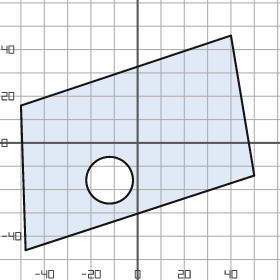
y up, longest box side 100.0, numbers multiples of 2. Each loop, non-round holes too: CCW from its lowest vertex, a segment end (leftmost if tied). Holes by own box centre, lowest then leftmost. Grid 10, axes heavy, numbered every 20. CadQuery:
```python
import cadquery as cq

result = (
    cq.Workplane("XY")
    .moveTo(-48.0, -46.0)
    .lineTo(50.0, -14.0)
    .lineTo(40.0, 46.0)
    .lineTo(-50.0, 16.0)
    .close()
    .moveTo(-12.0, -16.0)
    .circle(10.0)
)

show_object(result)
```